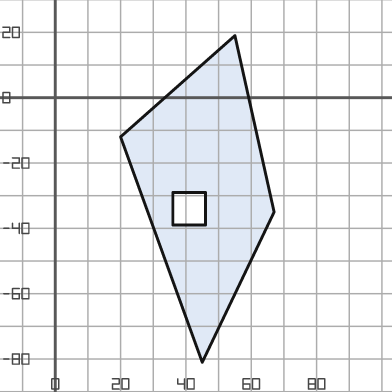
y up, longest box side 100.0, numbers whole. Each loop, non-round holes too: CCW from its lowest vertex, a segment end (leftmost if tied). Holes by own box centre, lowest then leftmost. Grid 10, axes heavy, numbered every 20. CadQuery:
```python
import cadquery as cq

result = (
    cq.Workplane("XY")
    .moveTo(45.0, -81.0)
    .lineTo(67.0, -35.0)
    .lineTo(55.0, 19.0)
    .lineTo(20.0, -12.0)
    .close()
    .moveTo(36.0, -39.0)
    .lineTo(46.0, -39.0)
    .lineTo(46.0, -29.0)
    .lineTo(36.0, -29.0)
    .close()
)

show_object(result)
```